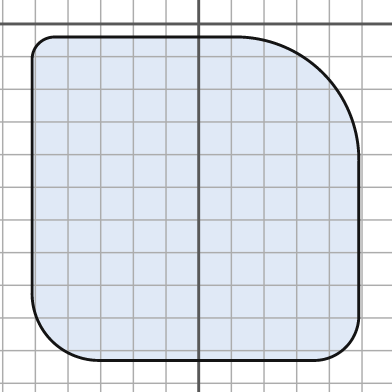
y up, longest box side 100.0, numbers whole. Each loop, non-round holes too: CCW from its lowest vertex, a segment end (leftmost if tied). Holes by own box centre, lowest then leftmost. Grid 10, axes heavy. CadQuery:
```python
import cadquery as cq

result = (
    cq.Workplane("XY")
    .moveTo(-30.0, -103.0)
    .lineTo(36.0, -103.0)
    .threePointArc((45.0, -99.0), (49.0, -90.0))
    .lineTo(49.0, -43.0)
    .threePointArc((38.0, -15.0), (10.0, -4.0))
    .lineTo(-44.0, -4.0)
    .threePointArc((-49.0, -6.0), (-51.0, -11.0))
    .lineTo(-51.0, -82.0)
    .threePointArc((-45.0, -97.0), (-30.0, -103.0))
    .close()
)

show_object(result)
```